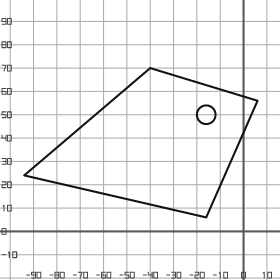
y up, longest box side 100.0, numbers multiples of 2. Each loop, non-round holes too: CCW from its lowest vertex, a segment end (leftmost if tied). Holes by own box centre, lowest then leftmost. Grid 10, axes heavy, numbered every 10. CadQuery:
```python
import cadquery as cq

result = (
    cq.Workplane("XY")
    .moveTo(-16.0, 6.0)
    .lineTo(6.0, 56.0)
    .lineTo(-40.0, 70.0)
    .lineTo(-94.0, 24.0)
    .close()
    .moveTo(-16.0, 50.0)
    .circle(4.0)
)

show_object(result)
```